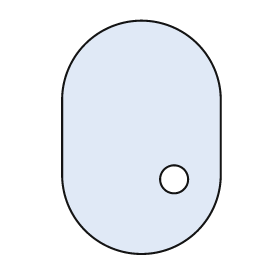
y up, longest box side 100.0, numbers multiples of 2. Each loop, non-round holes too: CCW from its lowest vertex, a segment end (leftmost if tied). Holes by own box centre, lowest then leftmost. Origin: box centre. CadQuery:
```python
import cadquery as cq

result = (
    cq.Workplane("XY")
    .moveTo(-34.0, -16.0)
    .threePointArc((0.0, -50.0), (34.0, -16.0))
    .lineTo(34.0, 16.0)
    .threePointArc((0.0, 50.0), (-34.0, 16.0))
    .close()
    .moveTo(14.0, -18.0)
    .circle(6.0)
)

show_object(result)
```